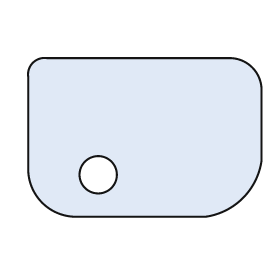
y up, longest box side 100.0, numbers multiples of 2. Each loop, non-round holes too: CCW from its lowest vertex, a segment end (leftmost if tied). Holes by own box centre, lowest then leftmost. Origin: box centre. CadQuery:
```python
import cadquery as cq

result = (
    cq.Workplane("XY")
    .moveTo(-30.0, -34.0)
    .lineTo(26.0, -34.0)
    .threePointArc((42.0, -26.0), (50.0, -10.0))
    .lineTo(50.0, 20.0)
    .threePointArc((46.0, 30.0), (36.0, 34.0))
    .lineTo(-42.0, 34.0)
    .threePointArc((-48.0, 32.0), (-50.0, 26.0))
    .lineTo(-50.0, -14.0)
    .threePointArc((-44.0, -28.0), (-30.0, -34.0))
    .close()
    .moveTo(-20.0, -16.0)
    .circle(8.0)
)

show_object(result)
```